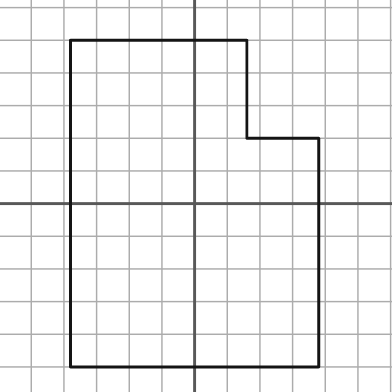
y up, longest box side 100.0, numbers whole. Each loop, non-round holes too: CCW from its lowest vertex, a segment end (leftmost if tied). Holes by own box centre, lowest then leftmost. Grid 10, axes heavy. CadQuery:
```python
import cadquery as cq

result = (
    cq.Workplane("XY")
    .moveTo(-38.0, -50.0)
    .lineTo(38.0, -50.0)
    .lineTo(38.0, 20.0)
    .lineTo(16.0, 20.0)
    .lineTo(16.0, 50.0)
    .lineTo(-38.0, 50.0)
    .close()
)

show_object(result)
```